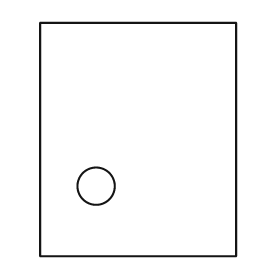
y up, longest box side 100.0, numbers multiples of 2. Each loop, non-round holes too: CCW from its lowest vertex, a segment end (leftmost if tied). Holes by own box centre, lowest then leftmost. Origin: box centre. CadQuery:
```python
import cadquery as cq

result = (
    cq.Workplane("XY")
    .moveTo(-42.0, -50.0)
    .lineTo(42.0, -50.0)
    .lineTo(42.0, 50.0)
    .lineTo(-42.0, 50.0)
    .close()
    .moveTo(-18.0, -20.0)
    .circle(8.0)
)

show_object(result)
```